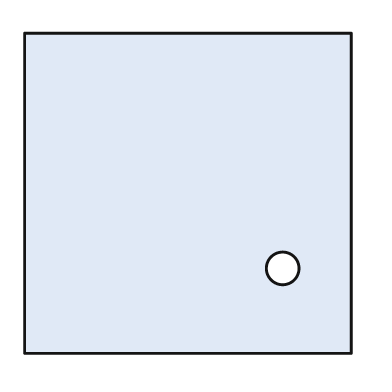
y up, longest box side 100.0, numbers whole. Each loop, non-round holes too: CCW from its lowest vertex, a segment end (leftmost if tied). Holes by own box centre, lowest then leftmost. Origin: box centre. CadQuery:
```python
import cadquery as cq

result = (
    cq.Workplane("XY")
    .moveTo(-50.0, -49.0)
    .lineTo(50.0, -49.0)
    .lineTo(50.0, 49.0)
    .lineTo(-50.0, 49.0)
    .close()
    .moveTo(29.0, -23.0)
    .circle(5.0)
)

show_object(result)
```